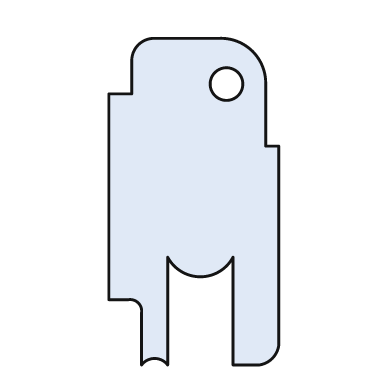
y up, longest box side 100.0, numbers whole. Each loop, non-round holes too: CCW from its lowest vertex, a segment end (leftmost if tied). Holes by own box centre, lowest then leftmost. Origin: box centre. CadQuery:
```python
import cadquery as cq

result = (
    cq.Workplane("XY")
    .moveTo(-16.0, -50.0)
    .threePointArc((-12.0, -48.0), (-8.0, -50.0))
    .lineTo(-8.0, -17.0)
    .threePointArc((2.0, -23.0), (12.0, -17.0))
    .lineTo(12.0, -50.0)
    .lineTo(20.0, -50.0)
    .threePointArc((24.0, -48.0), (26.0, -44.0))
    .lineTo(26.0, 17.0)
    .lineTo(22.0, 17.0)
    .lineTo(22.0, 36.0)
    .threePointArc((18.0, 46.0), (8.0, 50.0))
    .lineTo(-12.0, 50.0)
    .threePointArc((-17.0, 48.0), (-19.0, 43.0))
    .lineTo(-19.0, 33.0)
    .lineTo(-26.0, 33.0)
    .lineTo(-26.0, -30.0)
    .lineTo(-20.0, -30.0)
    .threePointArc((-17.0, -31.0), (-16.0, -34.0))
    .close()
    .moveTo(10.0, 36.0)
    .circle(5.0)
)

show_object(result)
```